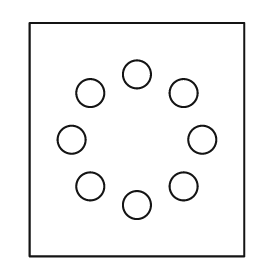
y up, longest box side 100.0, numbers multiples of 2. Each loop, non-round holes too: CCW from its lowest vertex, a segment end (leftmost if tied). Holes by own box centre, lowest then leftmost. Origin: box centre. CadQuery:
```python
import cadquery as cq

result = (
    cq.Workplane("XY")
    .moveTo(-46.0, -50.0)
    .lineTo(46.0, -50.0)
    .lineTo(46.0, 50.0)
    .lineTo(-46.0, 50.0)
    .close()
    .moveTo(0.0, -28.0)
    .circle(6.0)
    .moveTo(-20.0, -20.0)
    .circle(6.0)
    .moveTo(20.0, -20.0)
    .circle(6.0)
    .moveTo(-28.0, 0.0)
    .circle(6.0)
    .moveTo(28.0, 0.0)
    .circle(6.0)
    .moveTo(-20.0, 20.0)
    .circle(6.0)
    .moveTo(20.0, 20.0)
    .circle(6.0)
    .moveTo(0.0, 28.0)
    .circle(6.0)
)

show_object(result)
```